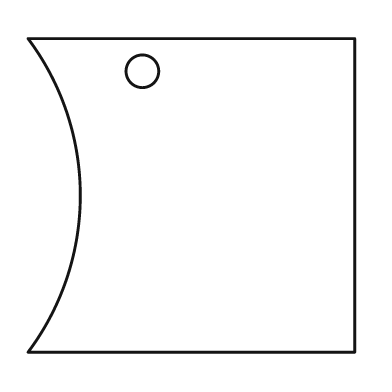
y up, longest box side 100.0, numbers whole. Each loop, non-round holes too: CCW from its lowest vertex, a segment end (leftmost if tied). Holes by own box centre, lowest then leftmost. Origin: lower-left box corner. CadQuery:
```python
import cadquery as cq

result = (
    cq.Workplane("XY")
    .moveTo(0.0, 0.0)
    .lineTo(100.0, 0.0)
    .lineTo(100.0, 96.0)
    .lineTo(0.0, 96.0)
    .threePointArc((16.0, 48.0), (0.0, 0.0))
    .close()
    .moveTo(35.0, 86.0)
    .circle(5.0)
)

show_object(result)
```